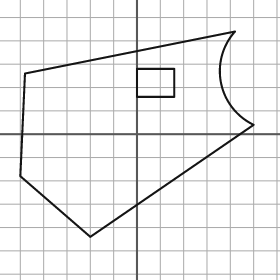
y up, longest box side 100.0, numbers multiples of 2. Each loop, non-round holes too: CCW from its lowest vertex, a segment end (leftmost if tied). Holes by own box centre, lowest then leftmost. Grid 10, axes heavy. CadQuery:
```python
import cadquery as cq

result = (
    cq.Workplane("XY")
    .moveTo(-20.0, -44.0)
    .lineTo(50.0, 4.0)
    .threePointArc((36.0, 22.0), (42.0, 44.0))
    .lineTo(-48.0, 26.0)
    .lineTo(-50.0, -18.0)
    .close()
    .moveTo(0.0, 16.0)
    .lineTo(16.0, 16.0)
    .lineTo(16.0, 28.0)
    .lineTo(0.0, 28.0)
    .close()
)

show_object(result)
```